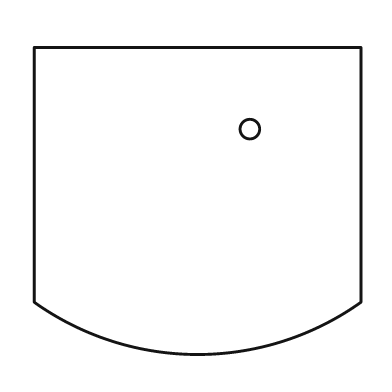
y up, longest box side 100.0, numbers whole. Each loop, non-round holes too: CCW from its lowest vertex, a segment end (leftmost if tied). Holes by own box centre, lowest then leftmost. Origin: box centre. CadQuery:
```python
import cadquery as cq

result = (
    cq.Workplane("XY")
    .moveTo(-50.0, -31.0)
    .threePointArc((0.0, -47.0), (50.0, -31.0))
    .lineTo(50.0, 47.0)
    .lineTo(-50.0, 47.0)
    .close()
    .moveTo(16.0, 22.0)
    .circle(3.0)
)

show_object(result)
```